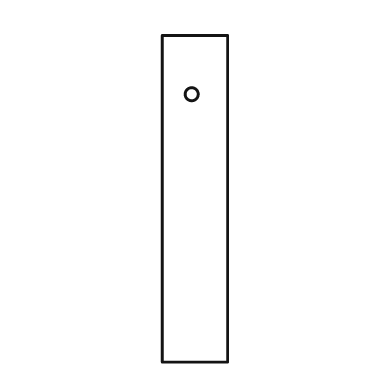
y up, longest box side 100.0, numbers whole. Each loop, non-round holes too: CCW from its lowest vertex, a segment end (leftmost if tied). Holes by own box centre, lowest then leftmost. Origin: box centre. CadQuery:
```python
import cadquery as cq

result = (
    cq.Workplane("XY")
    .moveTo(-10.0, -50.0)
    .lineTo(10.0, -50.0)
    .lineTo(10.0, 50.0)
    .lineTo(-10.0, 50.0)
    .close()
    .moveTo(-1.0, 32.0)
    .circle(2.0)
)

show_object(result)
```